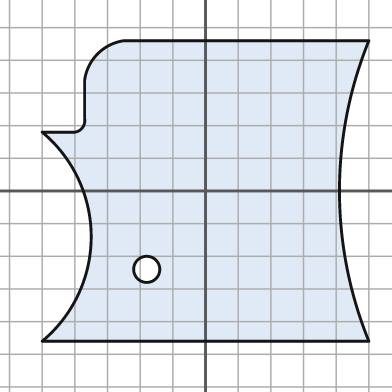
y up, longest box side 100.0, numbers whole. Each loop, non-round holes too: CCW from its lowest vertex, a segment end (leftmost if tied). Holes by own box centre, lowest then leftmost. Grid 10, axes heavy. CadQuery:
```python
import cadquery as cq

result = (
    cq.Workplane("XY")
    .moveTo(-50.0, -46.0)
    .lineTo(50.0, -46.0)
    .threePointArc((41.0, 0.0), (50.0, 46.0))
    .lineTo(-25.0, 46.0)
    .threePointArc((-33.0, 42.0), (-37.0, 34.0))
    .lineTo(-37.0, 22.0)
    .threePointArc((-38.0, 19.0), (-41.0, 18.0))
    .lineTo(-50.0, 18.0)
    .threePointArc((-35.0, -14.0), (-50.0, -46.0))
    .close()
    .moveTo(-18.0, -24.0)
    .circle(4.0)
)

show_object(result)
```